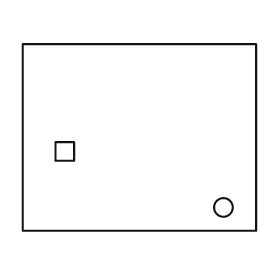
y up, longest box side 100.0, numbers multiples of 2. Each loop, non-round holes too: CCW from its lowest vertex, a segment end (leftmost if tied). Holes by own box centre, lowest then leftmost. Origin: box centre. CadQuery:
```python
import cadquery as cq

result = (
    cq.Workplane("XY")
    .moveTo(-50.0, -40.0)
    .lineTo(50.0, -40.0)
    .lineTo(50.0, 40.0)
    .lineTo(-50.0, 40.0)
    .close()
    .moveTo(36.0, -30.0)
    .circle(4.0)
    .moveTo(-36.0, -10.0)
    .lineTo(-28.0, -10.0)
    .lineTo(-28.0, -2.0)
    .lineTo(-36.0, -2.0)
    .close()
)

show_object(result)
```